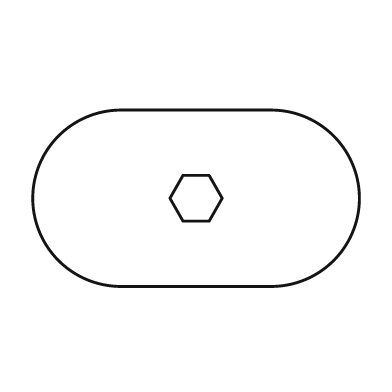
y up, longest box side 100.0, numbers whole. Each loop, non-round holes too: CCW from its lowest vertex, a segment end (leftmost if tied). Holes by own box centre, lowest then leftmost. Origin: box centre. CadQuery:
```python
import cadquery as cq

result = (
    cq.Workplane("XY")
    .moveTo(-23.0, -27.0)
    .lineTo(23.0, -27.0)
    .threePointArc((50.0, 0.0), (23.0, 27.0))
    .lineTo(-23.0, 27.0)
    .threePointArc((-50.0, 0.0), (-23.0, -27.0))
    .close()
    .moveTo(-4.0, -7.0)
    .lineTo(4.0, -7.0)
    .lineTo(8.0, 0.0)
    .lineTo(4.0, 7.0)
    .lineTo(-4.0, 7.0)
    .lineTo(-8.0, 0.0)
    .close()
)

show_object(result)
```